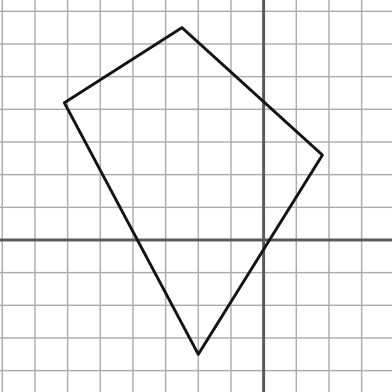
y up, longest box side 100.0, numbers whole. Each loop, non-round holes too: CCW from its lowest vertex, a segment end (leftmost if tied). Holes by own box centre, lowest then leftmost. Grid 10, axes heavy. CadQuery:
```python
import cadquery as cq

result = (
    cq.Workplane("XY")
    .moveTo(-20.0, -35.0)
    .lineTo(18.0, 26.0)
    .lineTo(-25.0, 65.0)
    .lineTo(-61.0, 42.0)
    .close()
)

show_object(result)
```